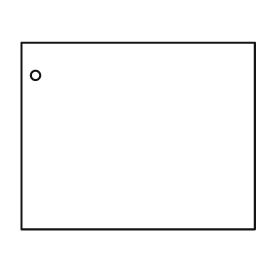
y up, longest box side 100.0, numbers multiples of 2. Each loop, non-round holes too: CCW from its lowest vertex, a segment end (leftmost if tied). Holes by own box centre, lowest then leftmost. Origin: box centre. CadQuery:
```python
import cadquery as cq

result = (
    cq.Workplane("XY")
    .moveTo(-50.0, -40.0)
    .lineTo(50.0, -40.0)
    .lineTo(50.0, 40.0)
    .lineTo(-50.0, 40.0)
    .close()
    .moveTo(-44.0, 26.0)
    .circle(2.0)
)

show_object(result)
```